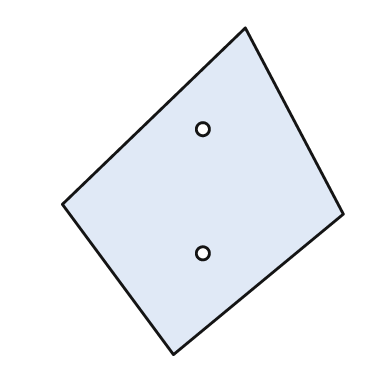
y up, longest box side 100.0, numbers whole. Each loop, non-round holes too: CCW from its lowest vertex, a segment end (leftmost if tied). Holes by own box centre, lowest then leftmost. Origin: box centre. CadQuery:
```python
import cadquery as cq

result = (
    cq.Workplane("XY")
    .moveTo(-9.0, -50.0)
    .lineTo(43.0, -7.0)
    .lineTo(13.0, 50.0)
    .lineTo(-43.0, -4.0)
    .close()
    .moveTo(0.0, -19.0)
    .circle(2.0)
    .moveTo(0.0, 19.0)
    .circle(2.0)
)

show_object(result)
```